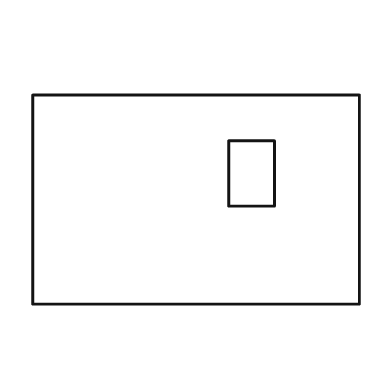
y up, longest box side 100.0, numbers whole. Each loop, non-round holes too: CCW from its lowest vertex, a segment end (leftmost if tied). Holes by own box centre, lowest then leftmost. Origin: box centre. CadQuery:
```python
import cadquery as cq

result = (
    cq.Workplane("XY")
    .moveTo(-50.0, -32.0)
    .lineTo(50.0, -32.0)
    .lineTo(50.0, 32.0)
    .lineTo(-50.0, 32.0)
    .close()
    .moveTo(10.0, -2.0)
    .lineTo(24.0, -2.0)
    .lineTo(24.0, 18.0)
    .lineTo(10.0, 18.0)
    .close()
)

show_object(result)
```